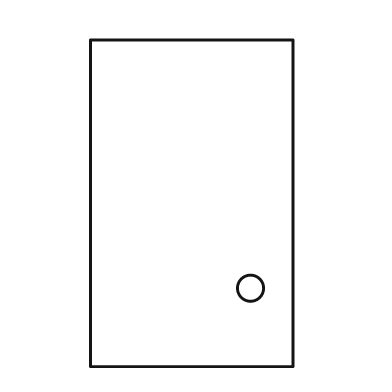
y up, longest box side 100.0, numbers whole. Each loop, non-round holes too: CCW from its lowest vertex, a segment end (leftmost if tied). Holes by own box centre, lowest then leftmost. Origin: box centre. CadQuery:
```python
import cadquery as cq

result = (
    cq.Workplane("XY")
    .moveTo(-31.0, -50.0)
    .lineTo(31.0, -50.0)
    .lineTo(31.0, 50.0)
    .lineTo(-31.0, 50.0)
    .close()
    .moveTo(18.0, -26.0)
    .circle(4.0)
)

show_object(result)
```